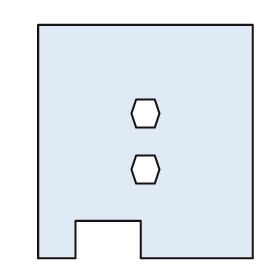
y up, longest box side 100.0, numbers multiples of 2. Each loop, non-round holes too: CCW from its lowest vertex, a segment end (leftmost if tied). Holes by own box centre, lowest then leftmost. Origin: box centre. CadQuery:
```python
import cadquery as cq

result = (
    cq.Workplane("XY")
    .moveTo(-46.0, -50.0)
    .lineTo(-30.0, -50.0)
    .lineTo(-30.0, -34.0)
    .lineTo(-2.0, -34.0)
    .lineTo(-2.0, -50.0)
    .lineTo(46.0, -50.0)
    .lineTo(46.0, 50.0)
    .lineTo(-46.0, 50.0)
    .close()
    .moveTo(-4.0, -18.0)
    .lineTo(4.0, -18.0)
    .lineTo(6.0, -12.0)
    .lineTo(4.0, -6.0)
    .lineTo(-4.0, -6.0)
    .lineTo(-6.0, -12.0)
    .close()
    .moveTo(-4.0, 6.0)
    .lineTo(4.0, 6.0)
    .lineTo(6.0, 12.0)
    .lineTo(4.0, 18.0)
    .lineTo(-4.0, 18.0)
    .lineTo(-6.0, 12.0)
    .close()
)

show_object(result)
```